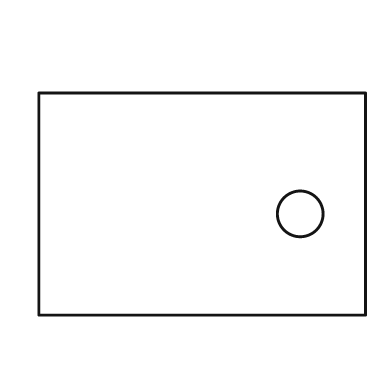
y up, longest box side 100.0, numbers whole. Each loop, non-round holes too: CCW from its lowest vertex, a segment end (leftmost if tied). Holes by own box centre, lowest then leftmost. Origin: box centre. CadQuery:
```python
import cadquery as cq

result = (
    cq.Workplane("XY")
    .moveTo(-50.0, -34.0)
    .lineTo(50.0, -34.0)
    .lineTo(50.0, 34.0)
    .lineTo(-50.0, 34.0)
    .close()
    .moveTo(30.0, -3.0)
    .circle(7.0)
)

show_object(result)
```